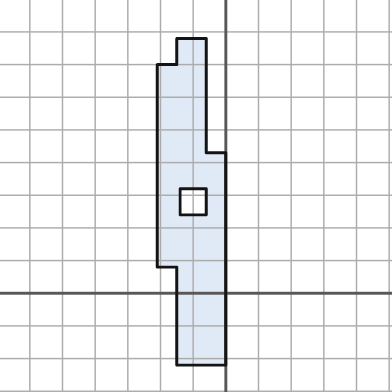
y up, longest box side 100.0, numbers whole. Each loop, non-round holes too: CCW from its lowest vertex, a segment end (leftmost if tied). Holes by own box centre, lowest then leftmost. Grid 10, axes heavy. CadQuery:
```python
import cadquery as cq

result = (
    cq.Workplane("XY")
    .moveTo(-15.0, -22.0)
    .lineTo(0.0, -22.0)
    .lineTo(0.0, 43.0)
    .lineTo(-6.0, 43.0)
    .lineTo(-6.0, 78.0)
    .lineTo(-15.0, 78.0)
    .lineTo(-15.0, 70.0)
    .lineTo(-21.0, 70.0)
    .lineTo(-21.0, 8.0)
    .lineTo(-15.0, 8.0)
    .close()
    .moveTo(-14.0, 24.0)
    .lineTo(-6.0, 24.0)
    .lineTo(-6.0, 32.0)
    .lineTo(-14.0, 32.0)
    .close()
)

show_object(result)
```